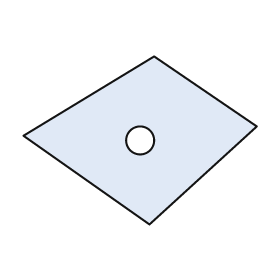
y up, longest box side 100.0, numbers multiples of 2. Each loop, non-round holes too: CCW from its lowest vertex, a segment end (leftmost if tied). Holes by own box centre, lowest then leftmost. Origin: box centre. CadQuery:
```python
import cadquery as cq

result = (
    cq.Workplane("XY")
    .moveTo(4.0, -36.0)
    .lineTo(50.0, 6.0)
    .lineTo(6.0, 36.0)
    .lineTo(-50.0, 2.0)
    .close()
    .moveTo(0.0, 0.0)
    .circle(6.0)
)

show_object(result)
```